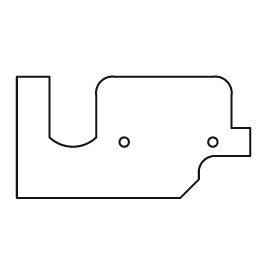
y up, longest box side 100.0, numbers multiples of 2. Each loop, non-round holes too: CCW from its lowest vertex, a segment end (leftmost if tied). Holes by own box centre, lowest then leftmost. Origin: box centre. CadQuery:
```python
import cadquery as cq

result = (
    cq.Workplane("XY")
    .moveTo(-50.0, -26.0)
    .lineTo(20.0, -26.0)
    .lineTo(28.0, -18.0)
    .lineTo(28.0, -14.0)
    .threePointArc((30.0, -10.0), (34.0, -8.0))
    .lineTo(50.0, -8.0)
    .lineTo(50.0, 4.0)
    .lineTo(42.0, 4.0)
    .lineTo(42.0, 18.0)
    .threePointArc((40.0, 24.0), (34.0, 26.0))
    .lineTo(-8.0, 26.0)
    .threePointArc((-14.0, 24.0), (-16.0, 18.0))
    .lineTo(-16.0, 0.0)
    .threePointArc((-26.0, -4.0), (-36.0, 0.0))
    .lineTo(-36.0, 26.0)
    .lineTo(-50.0, 26.0)
    .close()
    .moveTo(-4.0, -2.0)
    .circle(2.0)
    .moveTo(34.0, -2.0)
    .circle(2.0)
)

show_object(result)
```